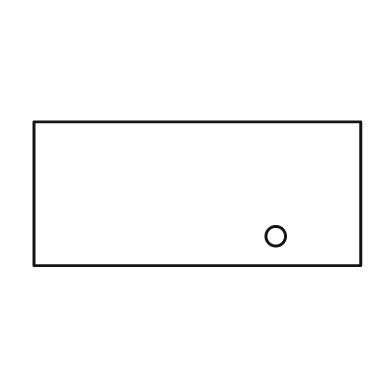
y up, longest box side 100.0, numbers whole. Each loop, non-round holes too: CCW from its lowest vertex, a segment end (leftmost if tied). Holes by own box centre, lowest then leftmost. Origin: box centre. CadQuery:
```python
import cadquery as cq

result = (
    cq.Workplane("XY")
    .moveTo(-50.0, -22.0)
    .lineTo(50.0, -22.0)
    .lineTo(50.0, 22.0)
    .lineTo(-50.0, 22.0)
    .close()
    .moveTo(24.0, -13.0)
    .circle(3.0)
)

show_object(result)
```